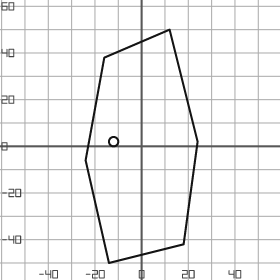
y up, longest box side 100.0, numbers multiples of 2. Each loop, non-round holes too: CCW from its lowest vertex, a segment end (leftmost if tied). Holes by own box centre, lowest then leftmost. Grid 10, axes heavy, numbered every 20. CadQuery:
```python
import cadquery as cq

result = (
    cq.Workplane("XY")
    .moveTo(-14.0, -50.0)
    .lineTo(18.0, -42.0)
    .lineTo(24.0, 2.0)
    .lineTo(12.0, 50.0)
    .lineTo(-16.0, 38.0)
    .lineTo(-24.0, -6.0)
    .close()
    .moveTo(-12.0, 2.0)
    .circle(2.0)
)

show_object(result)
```